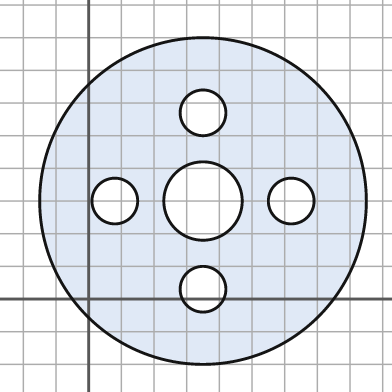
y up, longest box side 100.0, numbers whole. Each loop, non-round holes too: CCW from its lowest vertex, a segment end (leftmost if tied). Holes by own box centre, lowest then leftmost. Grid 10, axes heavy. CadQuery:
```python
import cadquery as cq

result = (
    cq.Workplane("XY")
    .moveTo(35.0, 30.0)
    .circle(50.0)
    .moveTo(35.0, 3.0)
    .circle(7.0)
    .moveTo(8.0, 30.0)
    .circle(7.0)
    .moveTo(35.0, 30.0)
    .circle(12.0)
    .moveTo(62.0, 30.0)
    .circle(7.0)
    .moveTo(35.0, 57.0)
    .circle(7.0)
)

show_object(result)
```